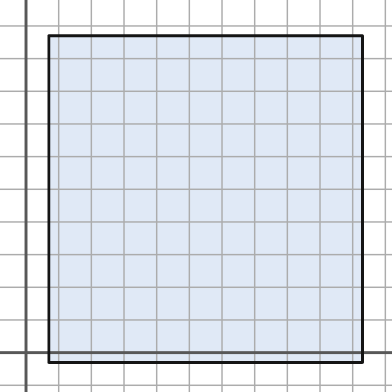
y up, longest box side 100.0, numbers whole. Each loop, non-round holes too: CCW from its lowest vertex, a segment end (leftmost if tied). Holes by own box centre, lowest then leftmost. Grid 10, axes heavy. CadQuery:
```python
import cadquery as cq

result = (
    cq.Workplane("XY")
    .moveTo(7.0, -3.0)
    .lineTo(103.0, -3.0)
    .lineTo(103.0, 97.0)
    .lineTo(7.0, 97.0)
    .close()
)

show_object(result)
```